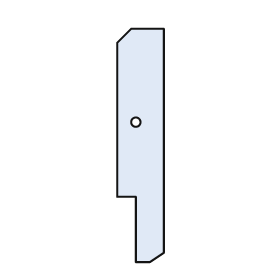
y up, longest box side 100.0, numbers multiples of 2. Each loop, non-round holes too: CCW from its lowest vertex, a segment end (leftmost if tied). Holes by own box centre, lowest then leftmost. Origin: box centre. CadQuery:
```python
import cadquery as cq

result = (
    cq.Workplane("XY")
    .moveTo(-2.0, -50.0)
    .lineTo(4.0, -50.0)
    .lineTo(10.0, -46.0)
    .lineTo(10.0, 50.0)
    .lineTo(-4.0, 50.0)
    .lineTo(-10.0, 44.0)
    .lineTo(-10.0, -22.0)
    .lineTo(-2.0, -22.0)
    .close()
    .moveTo(-2.0, 10.0)
    .circle(2.0)
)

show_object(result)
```